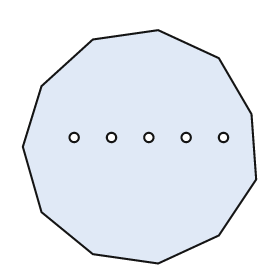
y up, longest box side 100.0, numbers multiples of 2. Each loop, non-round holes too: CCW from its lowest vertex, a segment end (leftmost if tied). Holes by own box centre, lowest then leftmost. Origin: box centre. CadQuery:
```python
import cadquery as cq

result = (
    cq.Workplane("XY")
    .moveTo(8.0, -50.0)
    .lineTo(34.0, -38.0)
    .lineTo(50.0, -14.0)
    .lineTo(48.0, 14.0)
    .lineTo(34.0, 38.0)
    .lineTo(8.0, 50.0)
    .lineTo(-20.0, 46.0)
    .lineTo(-42.0, 26.0)
    .lineTo(-50.0, 0.0)
    .lineTo(-42.0, -28.0)
    .lineTo(-20.0, -46.0)
    .close()
    .moveTo(-28.0, 4.0)
    .circle(2.0)
    .moveTo(-12.0, 4.0)
    .circle(2.0)
    .moveTo(4.0, 4.0)
    .circle(2.0)
    .moveTo(20.0, 4.0)
    .circle(2.0)
    .moveTo(36.0, 4.0)
    .circle(2.0)
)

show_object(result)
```